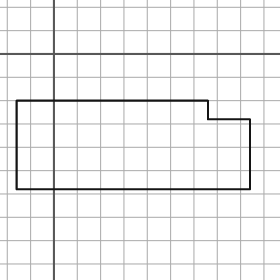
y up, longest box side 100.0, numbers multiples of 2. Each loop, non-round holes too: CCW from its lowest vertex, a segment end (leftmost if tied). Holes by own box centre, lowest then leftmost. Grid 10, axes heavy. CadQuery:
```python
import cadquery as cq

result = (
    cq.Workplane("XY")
    .moveTo(-16.0, -58.0)
    .lineTo(84.0, -58.0)
    .lineTo(84.0, -28.0)
    .lineTo(66.0, -28.0)
    .lineTo(66.0, -20.0)
    .lineTo(-16.0, -20.0)
    .close()
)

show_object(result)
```